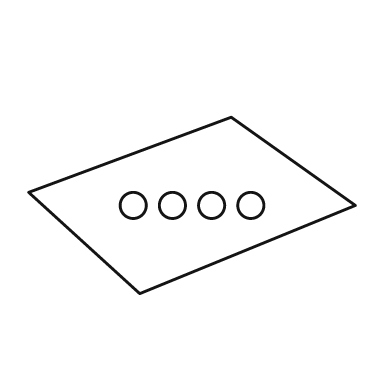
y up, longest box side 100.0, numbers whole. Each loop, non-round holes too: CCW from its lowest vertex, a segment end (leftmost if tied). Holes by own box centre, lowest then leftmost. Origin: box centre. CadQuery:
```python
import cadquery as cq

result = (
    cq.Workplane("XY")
    .moveTo(-16.0, -27.0)
    .lineTo(50.0, 0.0)
    .lineTo(12.0, 27.0)
    .lineTo(-50.0, 4.0)
    .close()
    .moveTo(-18.0, 0.0)
    .circle(4.0)
    .moveTo(-6.0, 0.0)
    .circle(4.0)
    .moveTo(6.0, 0.0)
    .circle(4.0)
    .moveTo(18.0, 0.0)
    .circle(4.0)
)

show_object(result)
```